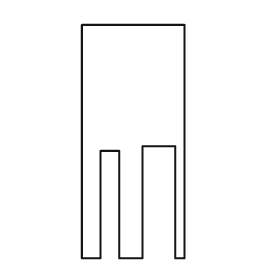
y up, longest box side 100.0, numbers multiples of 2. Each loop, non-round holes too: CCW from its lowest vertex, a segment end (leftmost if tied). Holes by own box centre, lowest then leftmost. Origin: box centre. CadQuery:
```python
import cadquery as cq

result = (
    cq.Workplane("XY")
    .moveTo(-22.0, -50.0)
    .lineTo(-14.0, -50.0)
    .lineTo(-14.0, -4.0)
    .lineTo(-6.0, -4.0)
    .lineTo(-6.0, -50.0)
    .lineTo(4.0, -50.0)
    .lineTo(4.0, -2.0)
    .lineTo(18.0, -2.0)
    .lineTo(18.0, -50.0)
    .lineTo(22.0, -50.0)
    .lineTo(22.0, 50.0)
    .lineTo(-22.0, 50.0)
    .close()
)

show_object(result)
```